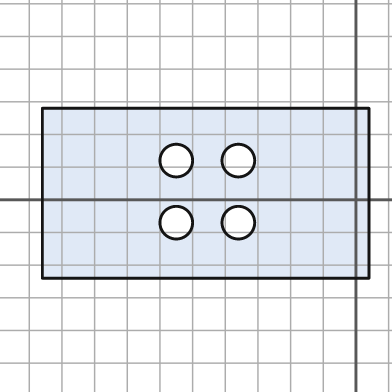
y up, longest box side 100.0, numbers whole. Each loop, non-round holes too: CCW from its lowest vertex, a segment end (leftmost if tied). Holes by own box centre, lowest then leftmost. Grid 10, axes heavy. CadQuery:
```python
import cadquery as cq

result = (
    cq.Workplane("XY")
    .moveTo(-96.0, -24.0)
    .lineTo(4.0, -24.0)
    .lineTo(4.0, 28.0)
    .lineTo(-96.0, 28.0)
    .close()
    .moveTo(-55.0, -7.0)
    .circle(5.0)
    .moveTo(-36.0, -7.0)
    .circle(5.0)
    .moveTo(-55.0, 12.0)
    .circle(5.0)
    .moveTo(-36.0, 12.0)
    .circle(5.0)
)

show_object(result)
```